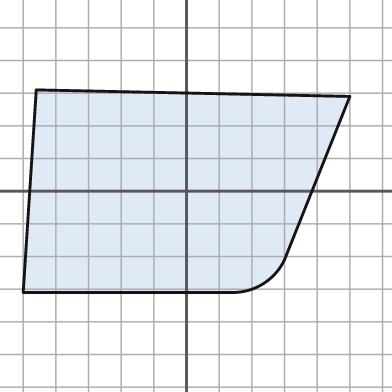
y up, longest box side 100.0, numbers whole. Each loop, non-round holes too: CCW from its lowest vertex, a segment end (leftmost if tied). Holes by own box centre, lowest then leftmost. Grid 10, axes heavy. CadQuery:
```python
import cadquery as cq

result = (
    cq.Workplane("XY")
    .moveTo(-50.0, -31.0)
    .lineTo(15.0, -31.0)
    .threePointArc((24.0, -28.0), (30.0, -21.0))
    .lineTo(50.0, 29.0)
    .lineTo(-46.0, 31.0)
    .close()
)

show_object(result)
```